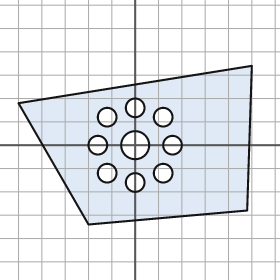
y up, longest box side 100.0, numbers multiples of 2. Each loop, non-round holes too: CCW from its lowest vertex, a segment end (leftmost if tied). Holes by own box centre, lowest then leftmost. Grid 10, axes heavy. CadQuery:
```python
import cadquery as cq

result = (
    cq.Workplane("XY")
    .moveTo(-20.0, -34.0)
    .lineTo(48.0, -28.0)
    .lineTo(50.0, 34.0)
    .lineTo(-50.0, 18.0)
    .close()
    .moveTo(0.0, -16.0)
    .circle(4.0)
    .moveTo(-12.0, -12.0)
    .circle(4.0)
    .moveTo(12.0, -12.0)
    .circle(4.0)
    .moveTo(-16.0, 0.0)
    .circle(4.0)
    .moveTo(0.0, 0.0)
    .circle(6.0)
    .moveTo(16.0, 0.0)
    .circle(4.0)
    .moveTo(-12.0, 12.0)
    .circle(4.0)
    .moveTo(12.0, 12.0)
    .circle(4.0)
    .moveTo(0.0, 16.0)
    .circle(4.0)
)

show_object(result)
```